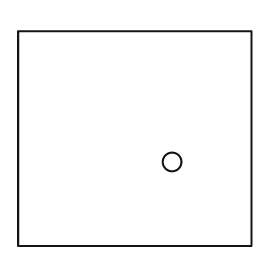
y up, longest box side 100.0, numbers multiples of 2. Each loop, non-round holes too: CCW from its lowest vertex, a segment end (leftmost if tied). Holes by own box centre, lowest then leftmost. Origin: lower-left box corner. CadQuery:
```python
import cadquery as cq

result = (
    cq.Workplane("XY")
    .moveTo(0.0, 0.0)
    .lineTo(100.0, 0.0)
    .lineTo(100.0, 92.0)
    .lineTo(0.0, 92.0)
    .close()
    .moveTo(66.0, 36.0)
    .circle(4.0)
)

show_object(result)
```